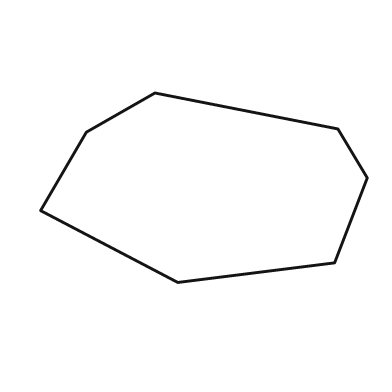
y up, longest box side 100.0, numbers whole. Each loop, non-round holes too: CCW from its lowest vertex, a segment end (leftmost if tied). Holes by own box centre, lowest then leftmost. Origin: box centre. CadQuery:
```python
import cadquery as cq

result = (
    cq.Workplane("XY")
    .moveTo(-8.0, -29.0)
    .lineTo(40.0, -23.0)
    .lineTo(50.0, 3.0)
    .lineTo(41.0, 18.0)
    .lineTo(-15.0, 29.0)
    .lineTo(-36.0, 17.0)
    .lineTo(-50.0, -7.0)
    .close()
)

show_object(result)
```